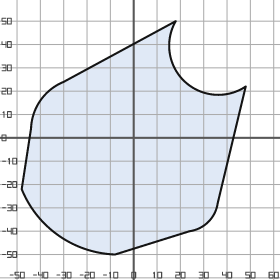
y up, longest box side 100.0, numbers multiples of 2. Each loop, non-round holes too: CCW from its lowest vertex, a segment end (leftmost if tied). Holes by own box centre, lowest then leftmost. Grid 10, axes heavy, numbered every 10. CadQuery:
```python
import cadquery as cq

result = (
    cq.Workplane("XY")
    .moveTo(-8.0, -50.0)
    .lineTo(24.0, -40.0)
    .threePointArc((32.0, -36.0), (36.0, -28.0))
    .lineTo(48.0, 22.0)
    .threePointArc((22.0, 24.0), (18.0, 50.0))
    .lineTo(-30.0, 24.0)
    .threePointArc((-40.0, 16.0), (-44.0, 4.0))
    .lineTo(-48.0, -22.0)
    .threePointArc((-32.0, -42.0), (-8.0, -50.0))
    .close()
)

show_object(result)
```